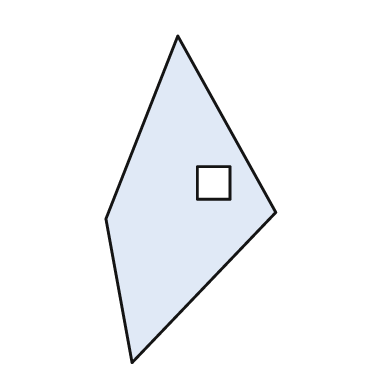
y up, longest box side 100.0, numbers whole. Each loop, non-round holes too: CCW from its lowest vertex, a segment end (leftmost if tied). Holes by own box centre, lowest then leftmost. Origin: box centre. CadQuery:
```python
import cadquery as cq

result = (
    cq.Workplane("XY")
    .moveTo(-18.0, -50.0)
    .lineTo(26.0, -4.0)
    .lineTo(-4.0, 50.0)
    .lineTo(-26.0, -6.0)
    .close()
    .moveTo(2.0, 0.0)
    .lineTo(12.0, 0.0)
    .lineTo(12.0, 10.0)
    .lineTo(2.0, 10.0)
    .close()
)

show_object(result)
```